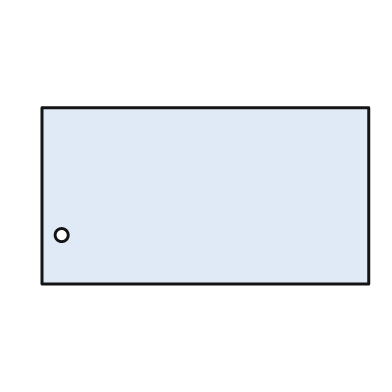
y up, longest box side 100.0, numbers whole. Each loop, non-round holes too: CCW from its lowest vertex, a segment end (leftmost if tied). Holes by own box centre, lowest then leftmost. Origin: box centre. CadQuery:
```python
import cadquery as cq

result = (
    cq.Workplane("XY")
    .moveTo(-50.0, -27.0)
    .lineTo(50.0, -27.0)
    .lineTo(50.0, 27.0)
    .lineTo(-50.0, 27.0)
    .close()
    .moveTo(-44.0, -12.0)
    .circle(2.0)
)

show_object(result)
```